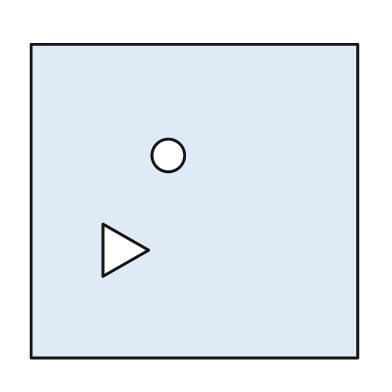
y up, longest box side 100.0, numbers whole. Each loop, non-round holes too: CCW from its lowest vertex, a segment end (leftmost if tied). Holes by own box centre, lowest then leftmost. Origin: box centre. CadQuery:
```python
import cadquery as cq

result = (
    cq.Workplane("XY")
    .moveTo(-50.0, -48.0)
    .lineTo(50.0, -48.0)
    .lineTo(50.0, 48.0)
    .lineTo(-50.0, 48.0)
    .close()
    .moveTo(-28.0, -23.0)
    .lineTo(-14.0, -15.0)
    .lineTo(-28.0, -7.0)
    .close()
    .moveTo(-8.0, 14.0)
    .circle(5.0)
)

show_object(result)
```